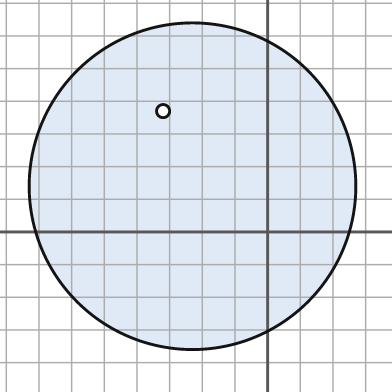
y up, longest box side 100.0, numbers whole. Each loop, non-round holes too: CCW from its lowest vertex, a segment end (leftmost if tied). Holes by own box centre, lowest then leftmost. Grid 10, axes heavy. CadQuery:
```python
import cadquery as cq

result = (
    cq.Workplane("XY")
    .moveTo(-23.0, 14.0)
    .circle(50.0)
    .moveTo(-32.0, 37.0)
    .circle(2.0)
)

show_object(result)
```